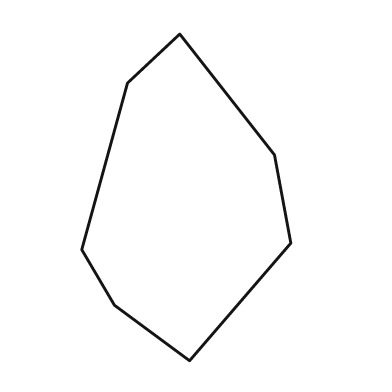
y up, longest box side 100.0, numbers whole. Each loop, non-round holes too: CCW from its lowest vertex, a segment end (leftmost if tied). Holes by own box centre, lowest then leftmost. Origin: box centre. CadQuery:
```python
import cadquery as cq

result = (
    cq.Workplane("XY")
    .moveTo(1.0, -50.0)
    .lineTo(32.0, -14.0)
    .lineTo(27.0, 13.0)
    .lineTo(-2.0, 50.0)
    .lineTo(-18.0, 35.0)
    .lineTo(-32.0, -16.0)
    .lineTo(-22.0, -33.0)
    .close()
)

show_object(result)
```